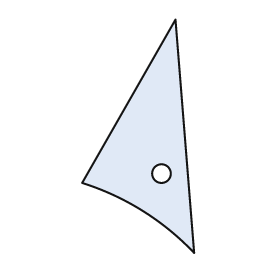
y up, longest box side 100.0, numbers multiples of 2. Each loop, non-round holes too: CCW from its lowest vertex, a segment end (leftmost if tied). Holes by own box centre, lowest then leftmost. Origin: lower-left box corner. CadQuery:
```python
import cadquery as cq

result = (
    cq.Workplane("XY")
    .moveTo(48.0, 0.0)
    .lineTo(40.0, 100.0)
    .lineTo(0.0, 30.0)
    .threePointArc((26.0, 18.0), (48.0, 0.0))
    .close()
    .moveTo(34.0, 34.0)
    .circle(4.0)
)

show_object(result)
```